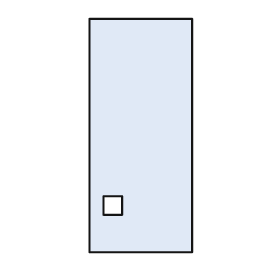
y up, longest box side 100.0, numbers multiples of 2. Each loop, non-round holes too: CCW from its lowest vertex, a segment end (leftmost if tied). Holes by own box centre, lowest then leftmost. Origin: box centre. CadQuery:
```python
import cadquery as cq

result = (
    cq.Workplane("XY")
    .moveTo(-22.0, -50.0)
    .lineTo(22.0, -50.0)
    .lineTo(22.0, 50.0)
    .lineTo(-22.0, 50.0)
    .close()
    .moveTo(-16.0, -34.0)
    .lineTo(-8.0, -34.0)
    .lineTo(-8.0, -26.0)
    .lineTo(-16.0, -26.0)
    .close()
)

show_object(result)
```